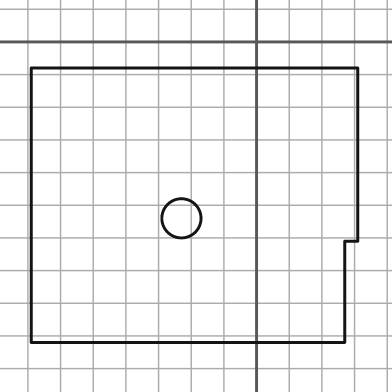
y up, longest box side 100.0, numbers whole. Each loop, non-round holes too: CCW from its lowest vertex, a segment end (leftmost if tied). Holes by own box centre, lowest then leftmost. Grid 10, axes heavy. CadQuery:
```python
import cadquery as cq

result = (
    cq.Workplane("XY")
    .moveTo(-69.0, -92.0)
    .lineTo(27.0, -92.0)
    .lineTo(27.0, -61.0)
    .lineTo(31.0, -61.0)
    .lineTo(31.0, -8.0)
    .lineTo(-69.0, -8.0)
    .close()
    .moveTo(-23.0, -54.0)
    .circle(6.0)
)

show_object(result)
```